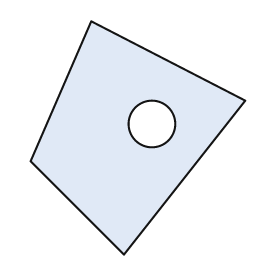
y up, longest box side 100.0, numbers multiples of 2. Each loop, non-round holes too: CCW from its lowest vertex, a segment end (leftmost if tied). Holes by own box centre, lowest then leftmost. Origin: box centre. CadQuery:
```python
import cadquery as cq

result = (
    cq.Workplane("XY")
    .moveTo(-6.0, -50.0)
    .lineTo(46.0, 16.0)
    .lineTo(-20.0, 50.0)
    .lineTo(-46.0, -10.0)
    .close()
    .moveTo(6.0, 6.0)
    .circle(10.0)
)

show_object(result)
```